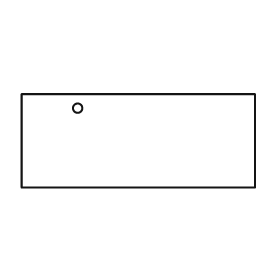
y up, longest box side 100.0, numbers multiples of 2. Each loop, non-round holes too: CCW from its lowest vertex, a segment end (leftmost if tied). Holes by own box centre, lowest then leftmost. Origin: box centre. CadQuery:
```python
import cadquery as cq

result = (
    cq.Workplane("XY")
    .moveTo(-50.0, -20.0)
    .lineTo(50.0, -20.0)
    .lineTo(50.0, 20.0)
    .lineTo(-50.0, 20.0)
    .close()
    .moveTo(-26.0, 14.0)
    .circle(2.0)
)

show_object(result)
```